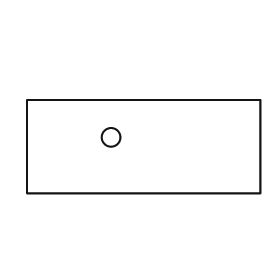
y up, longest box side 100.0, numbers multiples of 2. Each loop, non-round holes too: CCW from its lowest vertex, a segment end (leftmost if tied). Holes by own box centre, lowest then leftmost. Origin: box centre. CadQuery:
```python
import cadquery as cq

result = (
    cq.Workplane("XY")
    .moveTo(-50.0, -20.0)
    .lineTo(50.0, -20.0)
    .lineTo(50.0, 20.0)
    .lineTo(-50.0, 20.0)
    .close()
    .moveTo(-14.0, 4.0)
    .circle(4.0)
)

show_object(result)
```